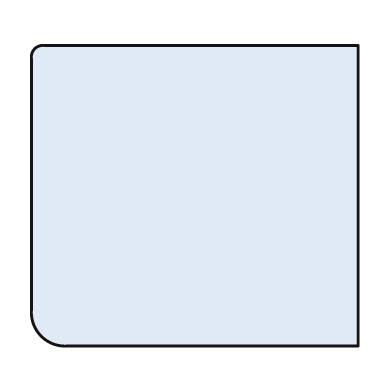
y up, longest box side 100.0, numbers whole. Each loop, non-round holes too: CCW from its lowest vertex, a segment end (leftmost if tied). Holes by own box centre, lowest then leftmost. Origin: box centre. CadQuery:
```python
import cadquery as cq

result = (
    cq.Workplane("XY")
    .moveTo(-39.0, -46.0)
    .lineTo(50.0, -46.0)
    .lineTo(50.0, 46.0)
    .lineTo(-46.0, 46.0)
    .threePointArc((-49.0, 45.0), (-50.0, 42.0))
    .lineTo(-50.0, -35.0)
    .threePointArc((-47.0, -43.0), (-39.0, -46.0))
    .close()
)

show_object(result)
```